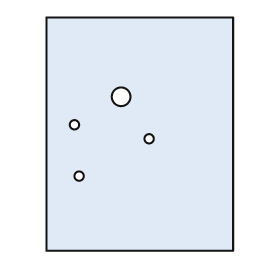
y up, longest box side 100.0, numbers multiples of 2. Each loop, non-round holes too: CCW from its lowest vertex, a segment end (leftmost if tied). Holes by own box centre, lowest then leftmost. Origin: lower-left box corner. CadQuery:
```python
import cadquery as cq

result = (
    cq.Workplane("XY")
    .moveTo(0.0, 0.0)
    .lineTo(80.0, 0.0)
    .lineTo(80.0, 100.0)
    .lineTo(0.0, 100.0)
    .close()
    .moveTo(14.0, 32.0)
    .circle(2.0)
    .moveTo(44.0, 48.0)
    .circle(2.0)
    .moveTo(12.0, 54.0)
    .circle(2.0)
    .moveTo(32.0, 66.0)
    .circle(4.0)
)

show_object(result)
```